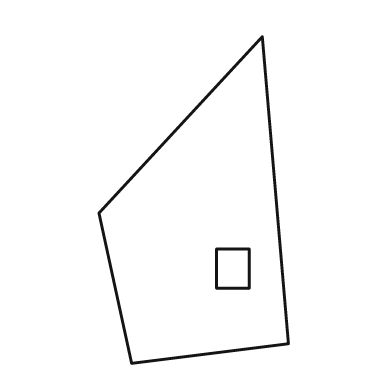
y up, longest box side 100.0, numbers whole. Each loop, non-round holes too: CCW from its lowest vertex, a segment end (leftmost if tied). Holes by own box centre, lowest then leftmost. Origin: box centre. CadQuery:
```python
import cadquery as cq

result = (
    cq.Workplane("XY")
    .moveTo(-19.0, -50.0)
    .lineTo(29.0, -44.0)
    .lineTo(21.0, 50.0)
    .lineTo(-29.0, -4.0)
    .close()
    .moveTo(7.0, -27.0)
    .lineTo(17.0, -27.0)
    .lineTo(17.0, -15.0)
    .lineTo(7.0, -15.0)
    .close()
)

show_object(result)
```